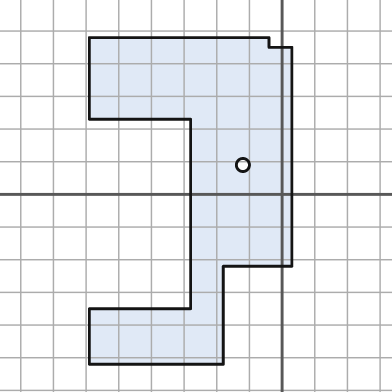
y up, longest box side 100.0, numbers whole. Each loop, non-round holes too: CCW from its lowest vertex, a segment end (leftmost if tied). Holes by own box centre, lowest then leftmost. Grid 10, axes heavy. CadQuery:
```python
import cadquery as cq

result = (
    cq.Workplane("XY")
    .moveTo(-59.0, -52.0)
    .lineTo(-18.0, -52.0)
    .lineTo(-18.0, -22.0)
    .lineTo(3.0, -22.0)
    .lineTo(3.0, 45.0)
    .lineTo(-4.0, 45.0)
    .lineTo(-4.0, 48.0)
    .lineTo(-59.0, 48.0)
    .lineTo(-59.0, 23.0)
    .lineTo(-28.0, 23.0)
    .lineTo(-28.0, -35.0)
    .lineTo(-59.0, -35.0)
    .close()
    .moveTo(-12.0, 9.0)
    .circle(2.0)
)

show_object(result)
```